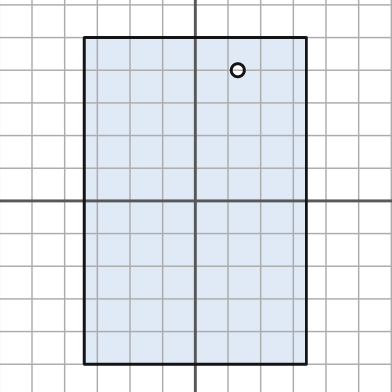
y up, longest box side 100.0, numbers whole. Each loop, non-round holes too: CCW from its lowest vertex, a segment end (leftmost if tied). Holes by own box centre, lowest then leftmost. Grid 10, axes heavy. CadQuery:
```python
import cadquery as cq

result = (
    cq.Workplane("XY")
    .moveTo(-34.0, -50.0)
    .lineTo(34.0, -50.0)
    .lineTo(34.0, 50.0)
    .lineTo(-34.0, 50.0)
    .close()
    .moveTo(13.0, 40.0)
    .circle(2.0)
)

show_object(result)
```